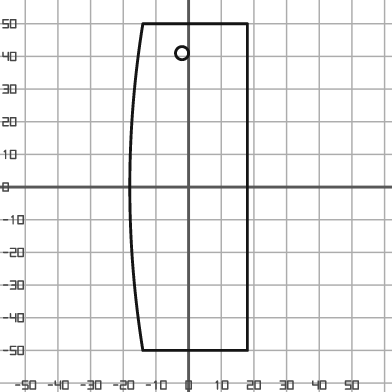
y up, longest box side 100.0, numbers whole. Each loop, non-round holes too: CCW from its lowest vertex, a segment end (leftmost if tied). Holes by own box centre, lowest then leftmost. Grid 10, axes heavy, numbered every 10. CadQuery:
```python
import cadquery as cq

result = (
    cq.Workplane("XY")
    .moveTo(-14.0, -50.0)
    .lineTo(18.0, -50.0)
    .lineTo(18.0, 50.0)
    .lineTo(-14.0, 50.0)
    .threePointArc((-18.0, 0.0), (-14.0, -50.0))
    .close()
    .moveTo(-2.0, 41.0)
    .circle(2.0)
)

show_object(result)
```